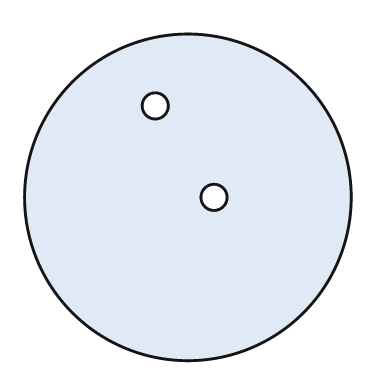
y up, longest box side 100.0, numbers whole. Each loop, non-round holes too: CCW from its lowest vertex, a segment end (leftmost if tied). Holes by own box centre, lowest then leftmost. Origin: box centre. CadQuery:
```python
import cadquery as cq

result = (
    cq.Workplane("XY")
    .moveTo(0.0, 0.0)
    .circle(50.0)
    .moveTo(8.0, 0.0)
    .circle(4.0)
    .moveTo(-10.0, 28.0)
    .circle(4.0)
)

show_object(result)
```